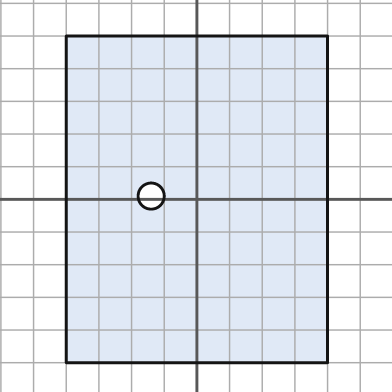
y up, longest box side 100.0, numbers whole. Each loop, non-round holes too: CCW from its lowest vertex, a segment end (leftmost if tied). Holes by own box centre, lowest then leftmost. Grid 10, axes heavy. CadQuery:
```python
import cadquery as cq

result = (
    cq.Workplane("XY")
    .moveTo(-40.0, -50.0)
    .lineTo(40.0, -50.0)
    .lineTo(40.0, 50.0)
    .lineTo(-40.0, 50.0)
    .close()
    .moveTo(-14.0, 1.0)
    .circle(4.0)
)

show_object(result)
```